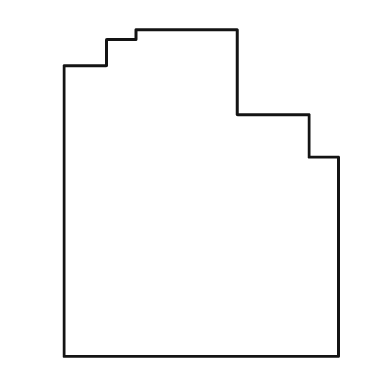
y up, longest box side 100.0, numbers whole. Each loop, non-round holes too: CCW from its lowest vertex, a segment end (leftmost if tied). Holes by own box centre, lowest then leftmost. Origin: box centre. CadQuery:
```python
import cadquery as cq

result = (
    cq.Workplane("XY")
    .moveTo(-42.0, -50.0)
    .lineTo(42.0, -50.0)
    .lineTo(42.0, 11.0)
    .lineTo(33.0, 11.0)
    .lineTo(33.0, 24.0)
    .lineTo(11.0, 24.0)
    .lineTo(11.0, 50.0)
    .lineTo(-20.0, 50.0)
    .lineTo(-20.0, 47.0)
    .lineTo(-29.0, 47.0)
    .lineTo(-29.0, 39.0)
    .lineTo(-42.0, 39.0)
    .close()
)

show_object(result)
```